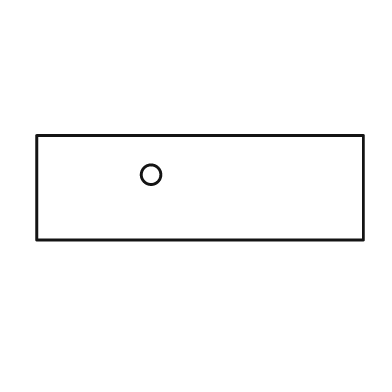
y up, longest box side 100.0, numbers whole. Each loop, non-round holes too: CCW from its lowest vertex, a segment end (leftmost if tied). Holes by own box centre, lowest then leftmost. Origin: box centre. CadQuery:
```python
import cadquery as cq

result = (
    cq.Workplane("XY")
    .moveTo(-50.0, -16.0)
    .lineTo(50.0, -16.0)
    .lineTo(50.0, 16.0)
    .lineTo(-50.0, 16.0)
    .close()
    .moveTo(-15.0, 4.0)
    .circle(3.0)
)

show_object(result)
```